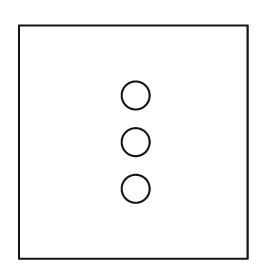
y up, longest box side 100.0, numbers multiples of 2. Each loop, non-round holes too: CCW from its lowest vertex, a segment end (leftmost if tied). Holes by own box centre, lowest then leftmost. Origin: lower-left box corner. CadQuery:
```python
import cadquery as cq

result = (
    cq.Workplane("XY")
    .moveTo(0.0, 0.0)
    .lineTo(98.0, 0.0)
    .lineTo(98.0, 100.0)
    .lineTo(0.0, 100.0)
    .close()
    .moveTo(50.0, 30.0)
    .circle(6.0)
    .moveTo(50.0, 50.0)
    .circle(6.0)
    .moveTo(50.0, 70.0)
    .circle(6.0)
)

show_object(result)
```